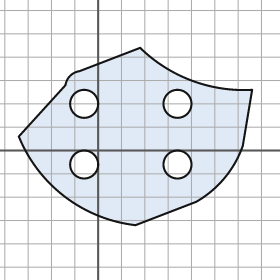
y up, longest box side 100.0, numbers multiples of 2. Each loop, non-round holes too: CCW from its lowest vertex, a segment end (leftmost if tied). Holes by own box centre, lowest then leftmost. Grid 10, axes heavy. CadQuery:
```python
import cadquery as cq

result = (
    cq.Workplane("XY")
    .moveTo(16.0, -32.0)
    .lineTo(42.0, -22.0)
    .threePointArc((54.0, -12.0), (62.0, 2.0))
    .lineTo(66.0, 26.0)
    .threePointArc((40.0, 30.0), (18.0, 44.0))
    .lineTo(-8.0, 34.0)
    .threePointArc((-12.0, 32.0), (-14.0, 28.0))
    .lineTo(-34.0, 6.0)
    .threePointArc((-14.0, -20.0), (16.0, -32.0))
    .close()
    .moveTo(-6.0, -6.0)
    .circle(6.0)
    .moveTo(34.0, -6.0)
    .circle(6.0)
    .moveTo(-6.0, 20.0)
    .circle(6.0)
    .moveTo(34.0, 20.0)
    .circle(6.0)
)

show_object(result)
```